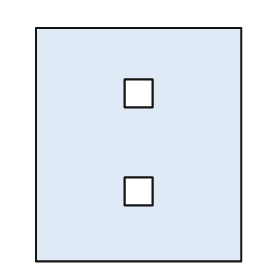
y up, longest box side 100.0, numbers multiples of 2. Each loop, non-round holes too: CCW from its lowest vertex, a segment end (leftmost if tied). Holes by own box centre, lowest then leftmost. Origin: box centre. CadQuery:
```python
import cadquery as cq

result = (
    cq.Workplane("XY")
    .moveTo(-44.0, -50.0)
    .lineTo(44.0, -50.0)
    .lineTo(44.0, 50.0)
    .lineTo(-44.0, 50.0)
    .close()
    .moveTo(-6.0, -26.0)
    .lineTo(6.0, -26.0)
    .lineTo(6.0, -14.0)
    .lineTo(-6.0, -14.0)
    .close()
    .moveTo(-6.0, 16.0)
    .lineTo(6.0, 16.0)
    .lineTo(6.0, 28.0)
    .lineTo(-6.0, 28.0)
    .close()
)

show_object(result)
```